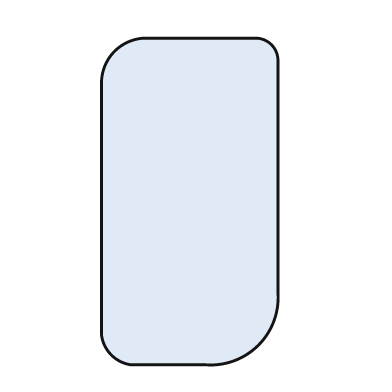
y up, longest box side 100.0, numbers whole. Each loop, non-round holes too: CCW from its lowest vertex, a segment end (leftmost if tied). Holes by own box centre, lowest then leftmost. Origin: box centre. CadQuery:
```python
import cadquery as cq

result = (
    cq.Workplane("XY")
    .moveTo(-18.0, -50.0)
    .lineTo(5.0, -50.0)
    .threePointArc((21.0, -44.0), (27.0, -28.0))
    .lineTo(27.0, 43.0)
    .threePointArc((25.0, 48.0), (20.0, 50.0))
    .lineTo(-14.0, 50.0)
    .threePointArc((-23.0, 46.0), (-27.0, 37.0))
    .lineTo(-27.0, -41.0)
    .threePointArc((-24.0, -47.0), (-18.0, -50.0))
    .close()
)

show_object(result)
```